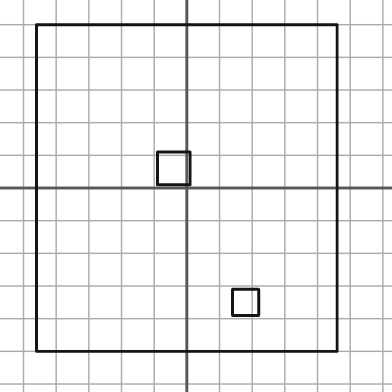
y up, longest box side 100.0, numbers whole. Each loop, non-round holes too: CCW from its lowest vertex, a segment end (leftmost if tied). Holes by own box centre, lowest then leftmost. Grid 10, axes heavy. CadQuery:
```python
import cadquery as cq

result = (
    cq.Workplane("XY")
    .moveTo(-46.0, -50.0)
    .lineTo(46.0, -50.0)
    .lineTo(46.0, 50.0)
    .lineTo(-46.0, 50.0)
    .close()
    .moveTo(14.0, -39.0)
    .lineTo(22.0, -39.0)
    .lineTo(22.0, -31.0)
    .lineTo(14.0, -31.0)
    .close()
    .moveTo(-9.0, 1.0)
    .lineTo(1.0, 1.0)
    .lineTo(1.0, 11.0)
    .lineTo(-9.0, 11.0)
    .close()
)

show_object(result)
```